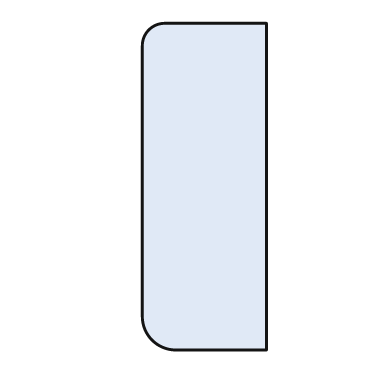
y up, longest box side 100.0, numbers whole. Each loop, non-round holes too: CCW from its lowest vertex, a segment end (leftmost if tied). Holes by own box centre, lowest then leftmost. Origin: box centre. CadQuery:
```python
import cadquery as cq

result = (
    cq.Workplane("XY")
    .moveTo(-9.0, -50.0)
    .lineTo(19.0, -50.0)
    .lineTo(19.0, 50.0)
    .lineTo(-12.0, 50.0)
    .threePointArc((-17.0, 48.0), (-19.0, 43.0))
    .lineTo(-19.0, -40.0)
    .threePointArc((-16.0, -47.0), (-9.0, -50.0))
    .close()
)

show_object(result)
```